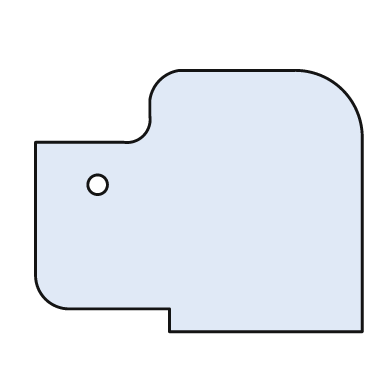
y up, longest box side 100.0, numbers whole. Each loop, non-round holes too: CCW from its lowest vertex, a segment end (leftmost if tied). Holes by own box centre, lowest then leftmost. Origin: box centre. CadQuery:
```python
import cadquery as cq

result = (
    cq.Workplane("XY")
    .moveTo(-9.0, -40.0)
    .lineTo(50.0, -40.0)
    .lineTo(50.0, 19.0)
    .threePointArc((44.0, 34.0), (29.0, 40.0))
    .lineTo(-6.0, 40.0)
    .threePointArc((-12.0, 37.0), (-15.0, 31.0))
    .lineTo(-15.0, 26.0)
    .threePointArc((-17.0, 20.0), (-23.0, 18.0))
    .lineTo(-50.0, 18.0)
    .lineTo(-50.0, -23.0)
    .threePointArc((-47.0, -30.0), (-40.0, -33.0))
    .lineTo(-9.0, -33.0)
    .close()
    .moveTo(-31.0, 5.0)
    .circle(3.0)
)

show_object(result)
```